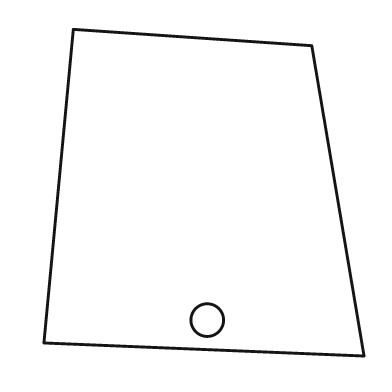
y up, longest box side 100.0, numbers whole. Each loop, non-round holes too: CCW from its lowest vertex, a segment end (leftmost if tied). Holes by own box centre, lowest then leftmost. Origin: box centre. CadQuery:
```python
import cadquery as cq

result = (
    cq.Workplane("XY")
    .moveTo(49.0, -50.0)
    .lineTo(33.0, 45.0)
    .lineTo(-40.0, 50.0)
    .lineTo(-49.0, -46.0)
    .close()
    .moveTo(1.0, -39.0)
    .circle(5.0)
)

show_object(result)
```